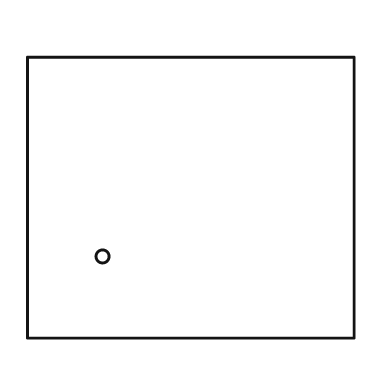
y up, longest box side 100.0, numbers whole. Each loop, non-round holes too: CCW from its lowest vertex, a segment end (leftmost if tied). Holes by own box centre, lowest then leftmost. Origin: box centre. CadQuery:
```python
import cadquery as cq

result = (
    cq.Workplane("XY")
    .moveTo(-50.0, -43.0)
    .lineTo(50.0, -43.0)
    .lineTo(50.0, 43.0)
    .lineTo(-50.0, 43.0)
    .close()
    .moveTo(-27.0, -18.0)
    .circle(2.0)
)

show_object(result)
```